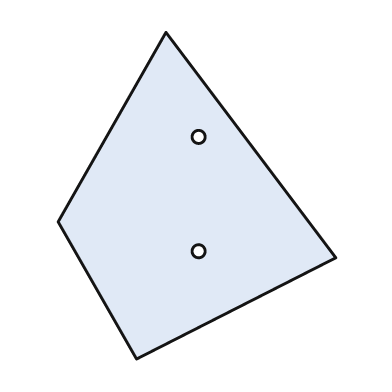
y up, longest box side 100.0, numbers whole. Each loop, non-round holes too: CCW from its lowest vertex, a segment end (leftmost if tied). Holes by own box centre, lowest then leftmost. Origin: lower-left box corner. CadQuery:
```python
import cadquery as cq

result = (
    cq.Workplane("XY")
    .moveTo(24.0, 0.0)
    .lineTo(85.0, 31.0)
    .lineTo(33.0, 100.0)
    .lineTo(0.0, 42.0)
    .close()
    .moveTo(43.0, 33.0)
    .circle(2.0)
    .moveTo(43.0, 68.0)
    .circle(2.0)
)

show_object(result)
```